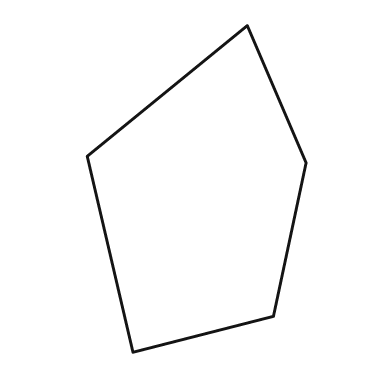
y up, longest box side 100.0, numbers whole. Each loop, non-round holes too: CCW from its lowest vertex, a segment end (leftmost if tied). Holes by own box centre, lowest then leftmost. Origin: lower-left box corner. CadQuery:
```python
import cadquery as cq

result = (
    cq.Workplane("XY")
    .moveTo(14.0, 0.0)
    .lineTo(57.0, 11.0)
    .lineTo(67.0, 58.0)
    .lineTo(49.0, 100.0)
    .lineTo(0.0, 60.0)
    .close()
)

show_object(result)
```